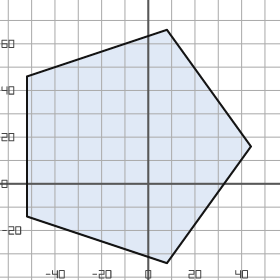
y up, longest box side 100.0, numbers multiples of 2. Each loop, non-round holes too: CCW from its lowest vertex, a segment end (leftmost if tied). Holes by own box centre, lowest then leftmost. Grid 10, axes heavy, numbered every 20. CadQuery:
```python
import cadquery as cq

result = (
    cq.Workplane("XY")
    .moveTo(8.0, -34.0)
    .lineTo(44.0, 16.0)
    .lineTo(8.0, 66.0)
    .lineTo(-52.0, 46.0)
    .lineTo(-52.0, -14.0)
    .close()
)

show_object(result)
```